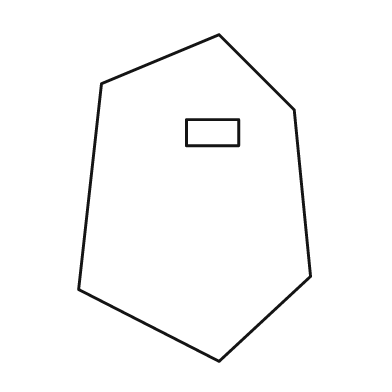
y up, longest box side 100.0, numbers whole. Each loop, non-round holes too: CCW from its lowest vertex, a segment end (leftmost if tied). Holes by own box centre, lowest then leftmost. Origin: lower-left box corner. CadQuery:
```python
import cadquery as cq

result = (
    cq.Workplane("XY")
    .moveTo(43.0, 0.0)
    .lineTo(71.0, 26.0)
    .lineTo(66.0, 77.0)
    .lineTo(43.0, 100.0)
    .lineTo(7.0, 85.0)
    .lineTo(0.0, 22.0)
    .close()
    .moveTo(33.0, 66.0)
    .lineTo(49.0, 66.0)
    .lineTo(49.0, 74.0)
    .lineTo(33.0, 74.0)
    .close()
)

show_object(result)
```